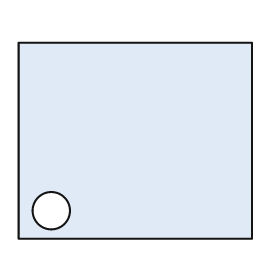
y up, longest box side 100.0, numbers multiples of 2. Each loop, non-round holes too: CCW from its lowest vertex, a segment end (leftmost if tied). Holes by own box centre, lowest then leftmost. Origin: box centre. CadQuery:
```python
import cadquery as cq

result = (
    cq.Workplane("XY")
    .moveTo(-50.0, -42.0)
    .lineTo(50.0, -42.0)
    .lineTo(50.0, 42.0)
    .lineTo(-50.0, 42.0)
    .close()
    .moveTo(-36.0, -30.0)
    .circle(8.0)
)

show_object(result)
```